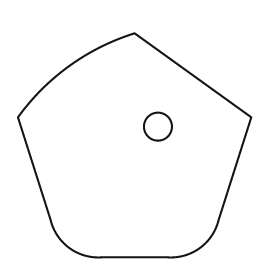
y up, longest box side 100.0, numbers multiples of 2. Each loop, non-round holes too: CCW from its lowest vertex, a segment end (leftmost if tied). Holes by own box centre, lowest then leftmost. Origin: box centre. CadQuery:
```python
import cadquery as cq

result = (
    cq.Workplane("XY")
    .moveTo(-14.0, -48.0)
    .lineTo(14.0, -48.0)
    .threePointArc((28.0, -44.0), (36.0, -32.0))
    .lineTo(50.0, 12.0)
    .lineTo(0.0, 48.0)
    .threePointArc((-28.0, 34.0), (-50.0, 12.0))
    .lineTo(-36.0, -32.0)
    .threePointArc((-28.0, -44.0), (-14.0, -48.0))
    .close()
    .moveTo(10.0, 8.0)
    .circle(6.0)
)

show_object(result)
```